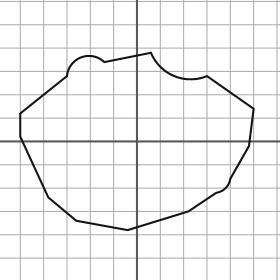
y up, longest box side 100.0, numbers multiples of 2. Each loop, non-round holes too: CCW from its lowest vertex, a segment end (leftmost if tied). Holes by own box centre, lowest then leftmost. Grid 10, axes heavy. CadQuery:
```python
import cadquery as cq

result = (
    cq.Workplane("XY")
    .moveTo(-4.0, -38.0)
    .lineTo(22.0, -30.0)
    .lineTo(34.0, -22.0)
    .threePointArc((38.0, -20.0), (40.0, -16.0))
    .lineTo(48.0, -2.0)
    .lineTo(50.0, 14.0)
    .lineTo(30.0, 28.0)
    .threePointArc((16.0, 28.0), (6.0, 38.0))
    .lineTo(-14.0, 34.0)
    .threePointArc((-24.0, 36.0), (-30.0, 28.0))
    .lineTo(-50.0, 12.0)
    .lineTo(-50.0, 2.0)
    .lineTo(-38.0, -24.0)
    .lineTo(-26.0, -34.0)
    .close()
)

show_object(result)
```